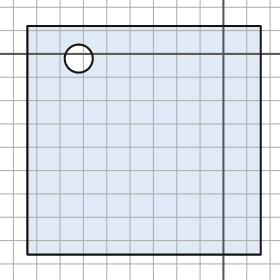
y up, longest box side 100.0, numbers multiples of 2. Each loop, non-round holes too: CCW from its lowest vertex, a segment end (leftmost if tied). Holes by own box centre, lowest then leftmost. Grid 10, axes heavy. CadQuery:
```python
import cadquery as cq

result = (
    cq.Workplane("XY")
    .moveTo(-84.0, -86.0)
    .lineTo(16.0, -86.0)
    .lineTo(16.0, 12.0)
    .lineTo(-84.0, 12.0)
    .close()
    .moveTo(-62.0, -2.0)
    .circle(6.0)
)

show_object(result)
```